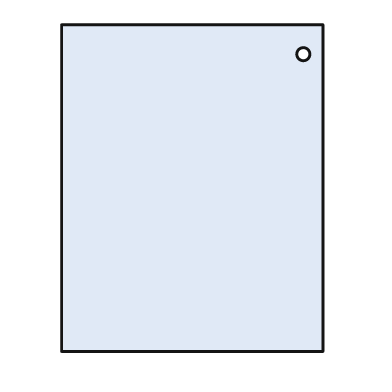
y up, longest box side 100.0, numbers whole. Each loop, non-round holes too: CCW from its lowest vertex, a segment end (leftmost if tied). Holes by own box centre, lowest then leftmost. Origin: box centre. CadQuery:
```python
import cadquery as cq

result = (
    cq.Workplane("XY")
    .moveTo(-40.0, -50.0)
    .lineTo(40.0, -50.0)
    .lineTo(40.0, 50.0)
    .lineTo(-40.0, 50.0)
    .close()
    .moveTo(34.0, 41.0)
    .circle(2.0)
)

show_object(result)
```